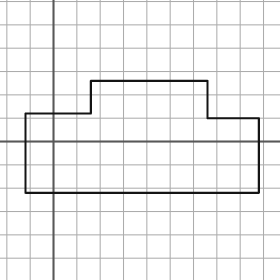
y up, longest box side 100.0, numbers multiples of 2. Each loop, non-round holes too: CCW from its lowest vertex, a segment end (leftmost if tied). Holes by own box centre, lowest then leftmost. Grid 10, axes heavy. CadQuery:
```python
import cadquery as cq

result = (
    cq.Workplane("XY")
    .moveTo(-12.0, -22.0)
    .lineTo(88.0, -22.0)
    .lineTo(88.0, 10.0)
    .lineTo(66.0, 10.0)
    .lineTo(66.0, 26.0)
    .lineTo(16.0, 26.0)
    .lineTo(16.0, 12.0)
    .lineTo(-12.0, 12.0)
    .close()
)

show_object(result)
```